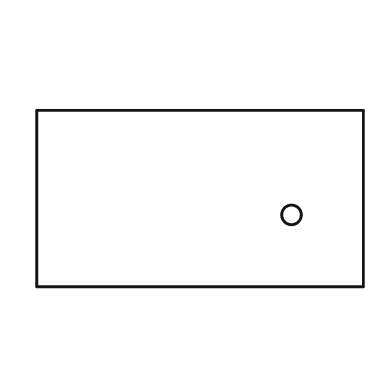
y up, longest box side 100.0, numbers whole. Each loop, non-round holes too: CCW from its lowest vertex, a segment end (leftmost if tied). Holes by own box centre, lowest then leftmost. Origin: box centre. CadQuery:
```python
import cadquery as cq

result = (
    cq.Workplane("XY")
    .moveTo(-50.0, -27.0)
    .lineTo(50.0, -27.0)
    .lineTo(50.0, 27.0)
    .lineTo(-50.0, 27.0)
    .close()
    .moveTo(28.0, -5.0)
    .circle(3.0)
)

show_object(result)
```